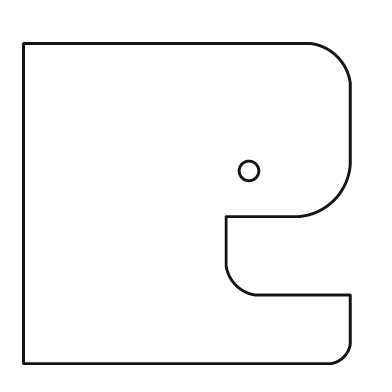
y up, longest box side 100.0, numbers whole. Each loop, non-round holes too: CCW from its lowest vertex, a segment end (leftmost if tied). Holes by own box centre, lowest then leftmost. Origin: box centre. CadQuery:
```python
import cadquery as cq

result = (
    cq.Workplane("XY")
    .moveTo(-50.0, -49.0)
    .lineTo(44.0, -49.0)
    .threePointArc((48.0, -47.0), (50.0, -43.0))
    .lineTo(50.0, -28.0)
    .lineTo(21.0, -28.0)
    .threePointArc((15.0, -25.0), (12.0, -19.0))
    .lineTo(12.0, -4.0)
    .lineTo(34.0, -4.0)
    .threePointArc((45.0, 1.0), (50.0, 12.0))
    .lineTo(50.0, 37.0)
    .threePointArc((46.0, 45.0), (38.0, 49.0))
    .lineTo(-50.0, 49.0)
    .close()
    .moveTo(19.0, 10.0)
    .circle(3.0)
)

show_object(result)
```